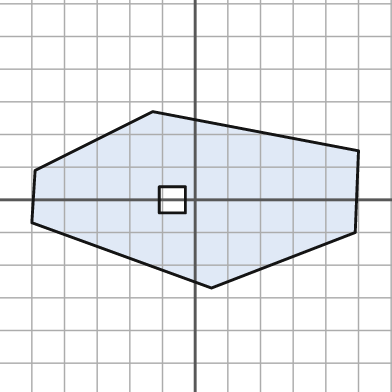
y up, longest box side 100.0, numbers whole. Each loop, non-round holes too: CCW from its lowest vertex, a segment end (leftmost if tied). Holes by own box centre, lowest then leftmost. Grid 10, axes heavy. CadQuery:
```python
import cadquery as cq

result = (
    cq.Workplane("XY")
    .moveTo(5.0, -27.0)
    .lineTo(49.0, -10.0)
    .lineTo(50.0, 15.0)
    .lineTo(-13.0, 27.0)
    .lineTo(-49.0, 9.0)
    .lineTo(-50.0, -7.0)
    .close()
    .moveTo(-11.0, -4.0)
    .lineTo(-3.0, -4.0)
    .lineTo(-3.0, 4.0)
    .lineTo(-11.0, 4.0)
    .close()
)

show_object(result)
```